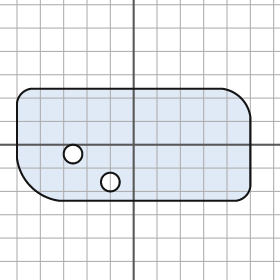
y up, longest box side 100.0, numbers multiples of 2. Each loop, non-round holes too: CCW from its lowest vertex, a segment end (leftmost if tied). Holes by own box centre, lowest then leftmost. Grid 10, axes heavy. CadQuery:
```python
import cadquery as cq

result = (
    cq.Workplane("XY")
    .moveTo(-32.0, -24.0)
    .lineTo(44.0, -24.0)
    .threePointArc((48.0, -22.0), (50.0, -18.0))
    .lineTo(50.0, 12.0)
    .threePointArc((46.0, 20.0), (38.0, 24.0))
    .lineTo(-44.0, 24.0)
    .threePointArc((-48.0, 22.0), (-50.0, 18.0))
    .lineTo(-50.0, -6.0)
    .threePointArc((-44.0, -18.0), (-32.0, -24.0))
    .close()
    .moveTo(-10.0, -16.0)
    .circle(4.0)
    .moveTo(-26.0, -4.0)
    .circle(4.0)
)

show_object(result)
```